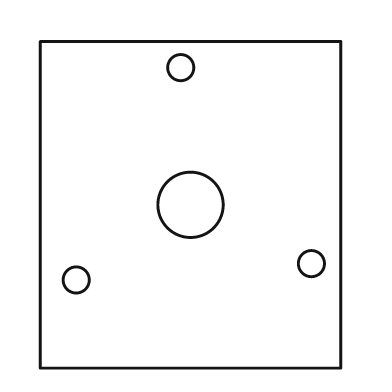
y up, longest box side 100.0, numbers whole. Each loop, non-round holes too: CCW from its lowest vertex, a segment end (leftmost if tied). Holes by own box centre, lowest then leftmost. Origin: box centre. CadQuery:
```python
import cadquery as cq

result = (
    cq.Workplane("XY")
    .moveTo(-46.0, -50.0)
    .lineTo(46.0, -50.0)
    .lineTo(46.0, 50.0)
    .lineTo(-46.0, 50.0)
    .close()
    .moveTo(-35.0, -23.0)
    .circle(4.0)
    .moveTo(37.0, -18.0)
    .circle(4.0)
    .moveTo(0.0, 0.0)
    .circle(10.0)
    .moveTo(-3.0, 42.0)
    .circle(4.0)
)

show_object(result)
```